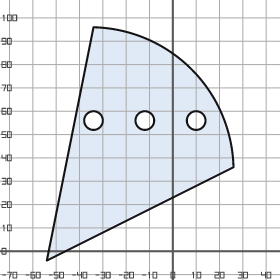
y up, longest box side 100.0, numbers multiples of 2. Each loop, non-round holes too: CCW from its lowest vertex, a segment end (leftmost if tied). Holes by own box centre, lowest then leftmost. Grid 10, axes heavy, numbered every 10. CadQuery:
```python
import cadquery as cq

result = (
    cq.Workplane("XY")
    .moveTo(-54.0, -4.0)
    .lineTo(26.0, 36.0)
    .threePointArc((8.0, 78.0), (-34.0, 96.0))
    .close()
    .moveTo(-34.0, 56.0)
    .circle(4.0)
    .moveTo(-12.0, 56.0)
    .circle(4.0)
    .moveTo(10.0, 56.0)
    .circle(4.0)
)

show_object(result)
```